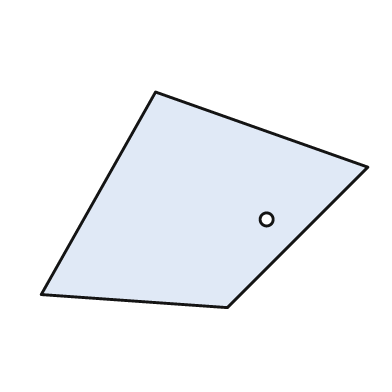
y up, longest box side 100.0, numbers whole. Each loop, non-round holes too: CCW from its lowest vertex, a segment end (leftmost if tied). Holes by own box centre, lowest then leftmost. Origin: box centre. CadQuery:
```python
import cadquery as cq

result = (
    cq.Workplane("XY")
    .moveTo(7.0, -33.0)
    .lineTo(50.0, 10.0)
    .lineTo(-15.0, 33.0)
    .lineTo(-50.0, -29.0)
    .close()
    .moveTo(19.0, -6.0)
    .circle(2.0)
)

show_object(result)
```